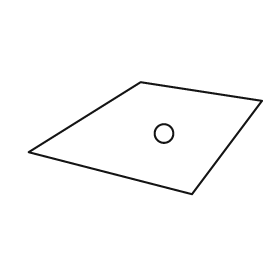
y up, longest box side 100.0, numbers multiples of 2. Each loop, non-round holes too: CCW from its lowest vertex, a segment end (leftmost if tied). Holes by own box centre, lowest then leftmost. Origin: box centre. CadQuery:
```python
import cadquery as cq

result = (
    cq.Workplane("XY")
    .moveTo(20.0, -24.0)
    .lineTo(50.0, 16.0)
    .lineTo(-2.0, 24.0)
    .lineTo(-50.0, -6.0)
    .close()
    .moveTo(8.0, 2.0)
    .circle(4.0)
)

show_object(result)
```